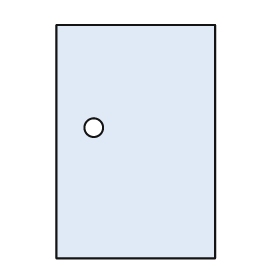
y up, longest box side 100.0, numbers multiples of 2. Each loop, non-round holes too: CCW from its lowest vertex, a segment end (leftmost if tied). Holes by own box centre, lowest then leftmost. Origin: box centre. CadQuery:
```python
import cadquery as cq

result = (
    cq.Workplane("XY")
    .moveTo(-34.0, -50.0)
    .lineTo(34.0, -50.0)
    .lineTo(34.0, 50.0)
    .lineTo(-34.0, 50.0)
    .close()
    .moveTo(-18.0, 6.0)
    .circle(4.0)
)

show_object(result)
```